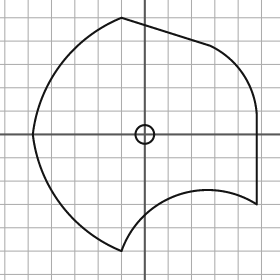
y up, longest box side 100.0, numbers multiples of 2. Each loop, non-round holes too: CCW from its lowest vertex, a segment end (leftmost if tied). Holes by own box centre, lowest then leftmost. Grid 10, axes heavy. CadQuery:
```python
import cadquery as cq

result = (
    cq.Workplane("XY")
    .moveTo(-10.0, -50.0)
    .threePointArc((14.0, -26.0), (48.0, -30.0))
    .lineTo(48.0, 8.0)
    .threePointArc((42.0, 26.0), (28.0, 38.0))
    .lineTo(-10.0, 50.0)
    .threePointArc((-36.0, 30.0), (-48.0, 0.0))
    .threePointArc((-36.0, -30.0), (-10.0, -50.0))
    .close()
    .moveTo(0.0, 0.0)
    .circle(4.0)
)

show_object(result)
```